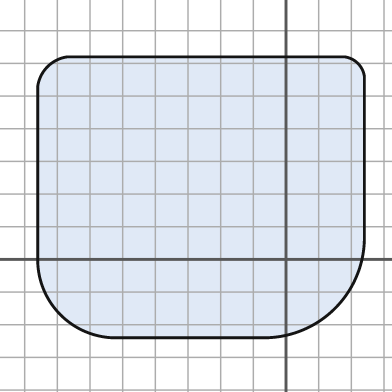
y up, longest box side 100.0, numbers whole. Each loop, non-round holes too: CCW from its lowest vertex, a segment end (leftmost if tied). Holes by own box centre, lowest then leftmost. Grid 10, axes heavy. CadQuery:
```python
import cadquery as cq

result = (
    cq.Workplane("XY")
    .moveTo(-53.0, -24.0)
    .lineTo(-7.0, -24.0)
    .threePointArc((15.0, -15.0), (24.0, 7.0))
    .lineTo(24.0, 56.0)
    .threePointArc((22.0, 60.0), (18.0, 62.0))
    .lineTo(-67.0, 62.0)
    .threePointArc((-73.0, 59.0), (-76.0, 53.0))
    .lineTo(-76.0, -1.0)
    .threePointArc((-69.0, -17.0), (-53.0, -24.0))
    .close()
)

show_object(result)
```